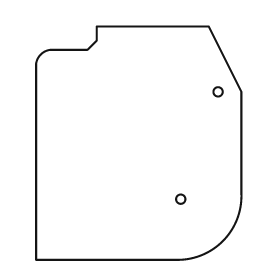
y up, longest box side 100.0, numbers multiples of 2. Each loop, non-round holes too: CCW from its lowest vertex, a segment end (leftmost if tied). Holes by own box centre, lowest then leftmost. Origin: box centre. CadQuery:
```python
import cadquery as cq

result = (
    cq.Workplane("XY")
    .moveTo(-44.0, -50.0)
    .lineTo(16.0, -50.0)
    .threePointArc((36.0, -42.0), (44.0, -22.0))
    .lineTo(44.0, 22.0)
    .lineTo(30.0, 50.0)
    .lineTo(-18.0, 50.0)
    .lineTo(-18.0, 44.0)
    .lineTo(-22.0, 40.0)
    .lineTo(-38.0, 40.0)
    .threePointArc((-42.0, 38.0), (-44.0, 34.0))
    .close()
    .moveTo(18.0, -24.0)
    .circle(2.0)
    .moveTo(34.0, 22.0)
    .circle(2.0)
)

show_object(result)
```